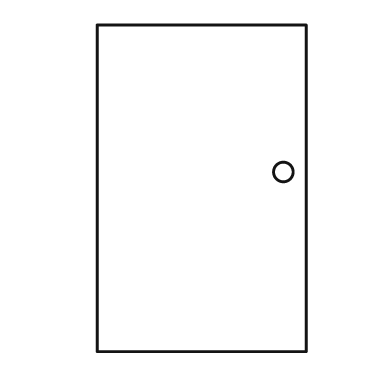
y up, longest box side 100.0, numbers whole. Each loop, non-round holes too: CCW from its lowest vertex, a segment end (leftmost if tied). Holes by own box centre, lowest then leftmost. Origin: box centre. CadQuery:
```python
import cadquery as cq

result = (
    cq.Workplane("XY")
    .moveTo(-32.0, -50.0)
    .lineTo(32.0, -50.0)
    .lineTo(32.0, 50.0)
    .lineTo(-32.0, 50.0)
    .close()
    .moveTo(25.0, 5.0)
    .circle(3.0)
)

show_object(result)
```